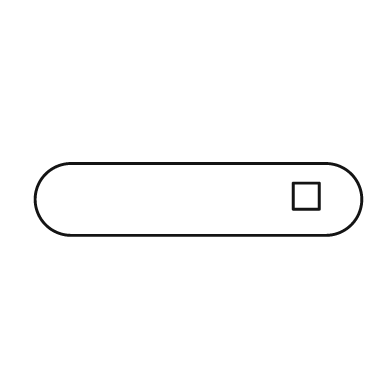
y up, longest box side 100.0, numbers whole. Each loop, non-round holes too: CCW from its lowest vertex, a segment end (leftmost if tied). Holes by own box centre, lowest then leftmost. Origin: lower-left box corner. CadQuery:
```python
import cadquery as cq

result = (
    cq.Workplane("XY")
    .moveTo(11.0, 0.0)
    .lineTo(89.0, 0.0)
    .threePointArc((100.0, 11.0), (89.0, 22.0))
    .lineTo(11.0, 22.0)
    .threePointArc((0.0, 11.0), (11.0, 0.0))
    .close()
    .moveTo(79.0, 8.0)
    .lineTo(87.0, 8.0)
    .lineTo(87.0, 16.0)
    .lineTo(79.0, 16.0)
    .close()
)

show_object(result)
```